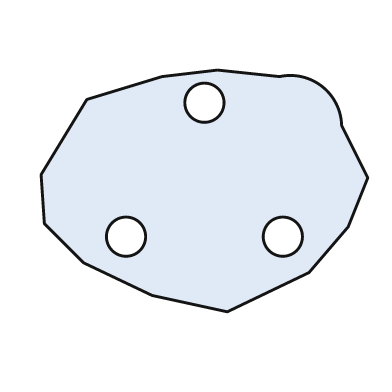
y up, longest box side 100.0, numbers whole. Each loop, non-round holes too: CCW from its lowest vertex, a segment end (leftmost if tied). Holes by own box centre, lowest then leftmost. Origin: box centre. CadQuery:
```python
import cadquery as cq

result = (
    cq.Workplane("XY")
    .moveTo(7.0, -37.0)
    .lineTo(32.0, -25.0)
    .lineTo(44.0, -11.0)
    .lineTo(50.0, 4.0)
    .lineTo(42.0, 20.0)
    .threePointArc((36.0, 32.0), (23.0, 35.0))
    .lineTo(4.0, 37.0)
    .lineTo(-13.0, 35.0)
    .lineTo(-36.0, 28.0)
    .lineTo(-50.0, 5.0)
    .lineTo(-49.0, -10.0)
    .lineTo(-37.0, -22.0)
    .lineTo(-16.0, -32.0)
    .close()
    .moveTo(-24.0, -14.0)
    .circle(6.0)
    .moveTo(24.0, -14.0)
    .circle(6.0)
    .moveTo(0.0, 27.0)
    .circle(6.0)
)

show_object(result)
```